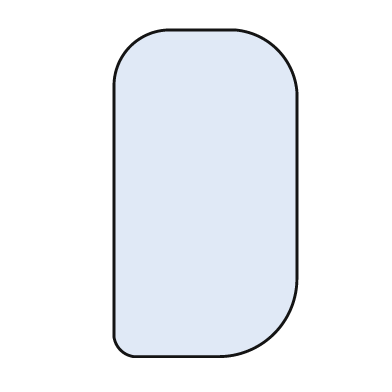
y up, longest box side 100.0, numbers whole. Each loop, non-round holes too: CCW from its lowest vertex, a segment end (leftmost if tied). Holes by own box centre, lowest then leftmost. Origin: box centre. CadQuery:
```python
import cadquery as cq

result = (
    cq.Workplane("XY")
    .moveTo(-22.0, -50.0)
    .lineTo(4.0, -50.0)
    .threePointArc((21.0, -43.0), (28.0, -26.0))
    .lineTo(28.0, 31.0)
    .threePointArc((22.0, 44.0), (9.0, 50.0))
    .lineTo(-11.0, 50.0)
    .threePointArc((-23.0, 45.0), (-28.0, 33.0))
    .lineTo(-28.0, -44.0)
    .threePointArc((-26.0, -48.0), (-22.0, -50.0))
    .close()
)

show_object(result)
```